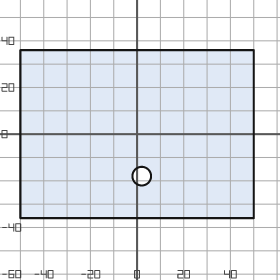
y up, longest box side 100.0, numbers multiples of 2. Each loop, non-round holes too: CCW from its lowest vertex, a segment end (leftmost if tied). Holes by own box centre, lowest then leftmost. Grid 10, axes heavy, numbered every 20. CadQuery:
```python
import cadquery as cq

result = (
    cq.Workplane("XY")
    .moveTo(-50.0, -36.0)
    .lineTo(50.0, -36.0)
    .lineTo(50.0, 36.0)
    .lineTo(-50.0, 36.0)
    .close()
    .moveTo(2.0, -18.0)
    .circle(4.0)
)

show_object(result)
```